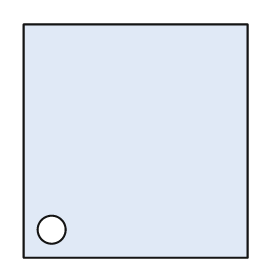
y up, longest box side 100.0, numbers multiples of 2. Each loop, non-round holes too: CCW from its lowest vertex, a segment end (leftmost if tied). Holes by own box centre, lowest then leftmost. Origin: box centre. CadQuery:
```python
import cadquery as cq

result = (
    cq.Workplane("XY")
    .moveTo(-48.0, -50.0)
    .lineTo(48.0, -50.0)
    .lineTo(48.0, 50.0)
    .lineTo(-48.0, 50.0)
    .close()
    .moveTo(-36.0, -38.0)
    .circle(6.0)
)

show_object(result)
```